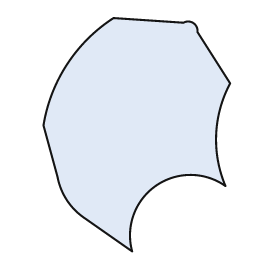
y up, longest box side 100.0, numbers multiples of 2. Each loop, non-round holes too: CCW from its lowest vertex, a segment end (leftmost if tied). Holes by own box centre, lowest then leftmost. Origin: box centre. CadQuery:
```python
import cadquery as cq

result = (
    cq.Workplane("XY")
    .moveTo(-2.0, -50.0)
    .threePointArc((8.0, -22.0), (38.0, -22.0))
    .threePointArc((34.0, 0.0), (40.0, 22.0))
    .lineTo(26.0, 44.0)
    .threePointArc((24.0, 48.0), (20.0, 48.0))
    .lineTo(-10.0, 50.0)
    .threePointArc((-30.0, 30.0), (-40.0, 4.0))
    .lineTo(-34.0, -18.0)
    .threePointArc((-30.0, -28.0), (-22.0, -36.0))
    .close()
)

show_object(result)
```